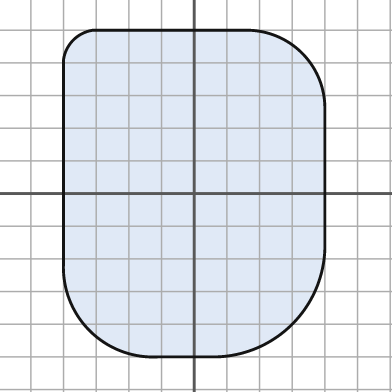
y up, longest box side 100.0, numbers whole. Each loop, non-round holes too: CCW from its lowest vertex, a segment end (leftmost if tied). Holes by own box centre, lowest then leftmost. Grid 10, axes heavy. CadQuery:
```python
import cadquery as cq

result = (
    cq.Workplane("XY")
    .moveTo(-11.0, -50.0)
    .lineTo(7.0, -50.0)
    .threePointArc((30.0, -40.0), (40.0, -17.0))
    .lineTo(40.0, 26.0)
    .threePointArc((33.0, 43.0), (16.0, 50.0))
    .lineTo(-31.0, 50.0)
    .threePointArc((-37.0, 47.0), (-40.0, 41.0))
    .lineTo(-40.0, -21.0)
    .threePointArc((-32.0, -42.0), (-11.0, -50.0))
    .close()
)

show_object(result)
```